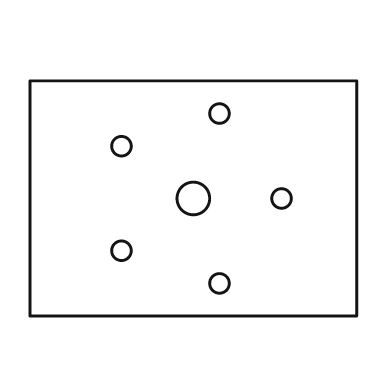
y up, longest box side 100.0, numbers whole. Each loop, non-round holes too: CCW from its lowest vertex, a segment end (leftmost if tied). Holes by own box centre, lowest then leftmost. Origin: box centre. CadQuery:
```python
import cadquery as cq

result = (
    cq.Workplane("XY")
    .moveTo(-50.0, -36.0)
    .lineTo(50.0, -36.0)
    .lineTo(50.0, 36.0)
    .lineTo(-50.0, 36.0)
    .close()
    .moveTo(8.0, -26.0)
    .circle(3.0)
    .moveTo(-22.0, -16.0)
    .circle(3.0)
    .moveTo(0.0, 0.0)
    .circle(5.0)
    .moveTo(27.0, 0.0)
    .circle(3.0)
    .moveTo(-22.0, 16.0)
    .circle(3.0)
    .moveTo(8.0, 26.0)
    .circle(3.0)
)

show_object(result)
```